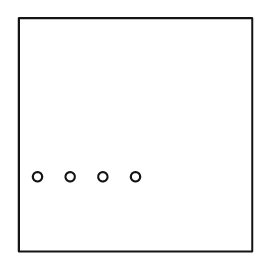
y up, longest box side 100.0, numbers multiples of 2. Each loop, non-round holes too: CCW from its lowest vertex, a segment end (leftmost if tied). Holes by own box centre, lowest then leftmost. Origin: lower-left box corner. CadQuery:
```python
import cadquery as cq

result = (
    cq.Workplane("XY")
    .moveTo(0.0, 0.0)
    .lineTo(100.0, 0.0)
    .lineTo(100.0, 100.0)
    .lineTo(0.0, 100.0)
    .close()
    .moveTo(8.0, 32.0)
    .circle(2.0)
    .moveTo(22.0, 32.0)
    .circle(2.0)
    .moveTo(36.0, 32.0)
    .circle(2.0)
    .moveTo(50.0, 32.0)
    .circle(2.0)
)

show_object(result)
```